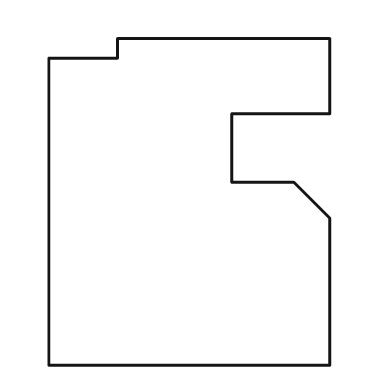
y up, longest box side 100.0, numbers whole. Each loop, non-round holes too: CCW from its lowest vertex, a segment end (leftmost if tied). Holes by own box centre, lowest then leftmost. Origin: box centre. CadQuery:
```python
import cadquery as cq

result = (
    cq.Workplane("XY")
    .moveTo(-43.0, -50.0)
    .lineTo(43.0, -50.0)
    .lineTo(43.0, -5.0)
    .lineTo(32.0, 6.0)
    .lineTo(13.0, 6.0)
    .lineTo(13.0, 27.0)
    .lineTo(43.0, 27.0)
    .lineTo(43.0, 50.0)
    .lineTo(-22.0, 50.0)
    .lineTo(-22.0, 44.0)
    .lineTo(-43.0, 44.0)
    .close()
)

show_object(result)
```